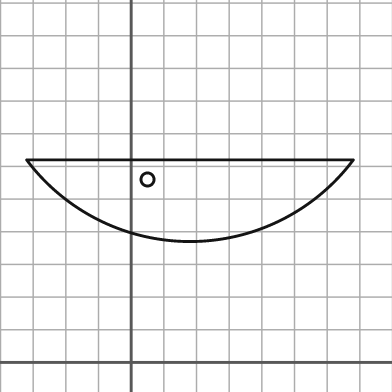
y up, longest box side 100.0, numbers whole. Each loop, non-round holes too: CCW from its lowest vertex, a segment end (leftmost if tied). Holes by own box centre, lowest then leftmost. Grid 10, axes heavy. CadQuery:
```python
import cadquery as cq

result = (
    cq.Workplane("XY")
    .moveTo(-32.0, 62.0)
    .threePointArc((18.0, 37.0), (68.0, 62.0))
    .close()
    .moveTo(5.0, 56.0)
    .circle(2.0)
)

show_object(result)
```